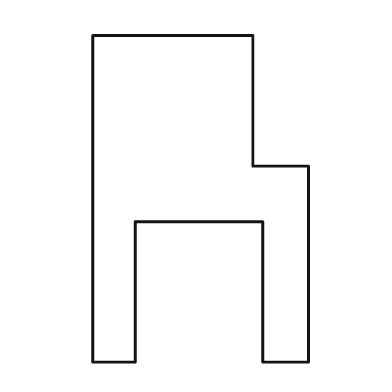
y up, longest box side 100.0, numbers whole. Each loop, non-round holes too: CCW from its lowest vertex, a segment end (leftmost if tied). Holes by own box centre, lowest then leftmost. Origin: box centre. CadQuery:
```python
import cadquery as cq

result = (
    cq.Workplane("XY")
    .moveTo(-33.0, -50.0)
    .lineTo(-20.0, -50.0)
    .lineTo(-20.0, -7.0)
    .lineTo(19.0, -7.0)
    .lineTo(19.0, -50.0)
    .lineTo(33.0, -50.0)
    .lineTo(33.0, 10.0)
    .lineTo(16.0, 10.0)
    .lineTo(16.0, 50.0)
    .lineTo(-33.0, 50.0)
    .close()
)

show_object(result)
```